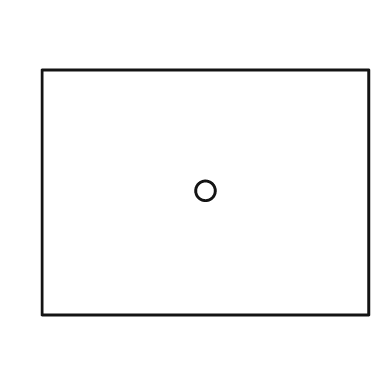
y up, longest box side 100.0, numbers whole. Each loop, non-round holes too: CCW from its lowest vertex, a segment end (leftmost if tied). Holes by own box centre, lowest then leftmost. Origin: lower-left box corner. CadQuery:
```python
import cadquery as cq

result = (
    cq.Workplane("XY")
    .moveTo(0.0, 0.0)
    .lineTo(100.0, 0.0)
    .lineTo(100.0, 75.0)
    .lineTo(0.0, 75.0)
    .close()
    .moveTo(50.0, 38.0)
    .circle(3.0)
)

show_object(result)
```